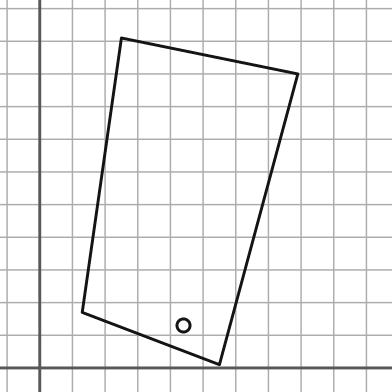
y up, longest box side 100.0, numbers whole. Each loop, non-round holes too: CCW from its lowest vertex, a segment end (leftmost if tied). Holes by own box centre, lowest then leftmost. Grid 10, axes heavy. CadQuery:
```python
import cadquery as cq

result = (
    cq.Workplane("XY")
    .moveTo(55.0, 1.0)
    .lineTo(79.0, 90.0)
    .lineTo(25.0, 101.0)
    .lineTo(13.0, 17.0)
    .close()
    .moveTo(44.0, 13.0)
    .circle(2.0)
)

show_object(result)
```